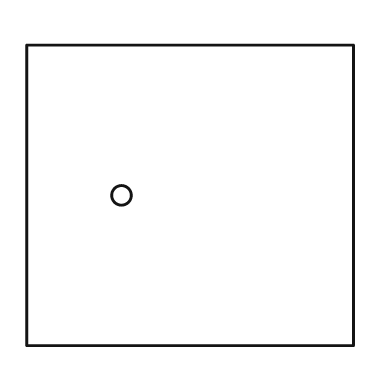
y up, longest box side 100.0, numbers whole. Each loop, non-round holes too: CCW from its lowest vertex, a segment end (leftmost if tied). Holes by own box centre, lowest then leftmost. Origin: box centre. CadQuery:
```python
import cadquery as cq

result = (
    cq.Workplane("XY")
    .moveTo(-50.0, -46.0)
    .lineTo(50.0, -46.0)
    .lineTo(50.0, 46.0)
    .lineTo(-50.0, 46.0)
    .close()
    .moveTo(-21.0, 0.0)
    .circle(3.0)
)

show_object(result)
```